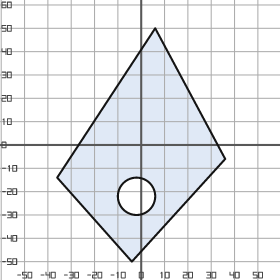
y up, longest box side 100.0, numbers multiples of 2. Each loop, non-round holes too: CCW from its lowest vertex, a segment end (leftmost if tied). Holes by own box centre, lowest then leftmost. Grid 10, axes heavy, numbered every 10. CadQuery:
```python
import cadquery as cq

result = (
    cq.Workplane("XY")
    .moveTo(-4.0, -50.0)
    .lineTo(36.0, -6.0)
    .lineTo(6.0, 50.0)
    .lineTo(-36.0, -14.0)
    .close()
    .moveTo(-2.0, -22.0)
    .circle(8.0)
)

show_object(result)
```